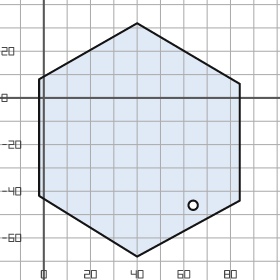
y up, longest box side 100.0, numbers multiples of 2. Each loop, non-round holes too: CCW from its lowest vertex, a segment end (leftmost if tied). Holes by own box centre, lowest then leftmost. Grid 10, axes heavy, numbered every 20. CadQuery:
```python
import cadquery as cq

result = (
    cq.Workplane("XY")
    .moveTo(40.0, -68.0)
    .lineTo(84.0, -44.0)
    .lineTo(84.0, 6.0)
    .lineTo(40.0, 32.0)
    .lineTo(-2.0, 8.0)
    .lineTo(-2.0, -42.0)
    .close()
    .moveTo(64.0, -46.0)
    .circle(2.0)
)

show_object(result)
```